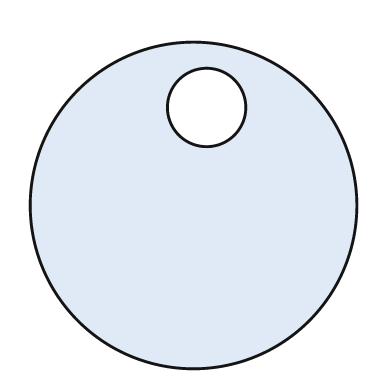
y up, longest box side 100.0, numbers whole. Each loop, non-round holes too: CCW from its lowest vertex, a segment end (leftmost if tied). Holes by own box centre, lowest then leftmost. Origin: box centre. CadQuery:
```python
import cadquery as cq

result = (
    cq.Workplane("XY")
    .moveTo(0.0, 0.0)
    .circle(50.0)
    .moveTo(4.0, 30.0)
    .circle(12.0)
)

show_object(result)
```